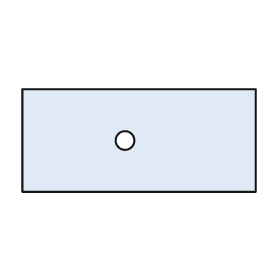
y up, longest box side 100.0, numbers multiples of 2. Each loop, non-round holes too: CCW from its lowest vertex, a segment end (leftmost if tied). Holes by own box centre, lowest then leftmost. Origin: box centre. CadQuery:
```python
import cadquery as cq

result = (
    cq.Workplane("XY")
    .moveTo(-50.0, -22.0)
    .lineTo(50.0, -22.0)
    .lineTo(50.0, 22.0)
    .lineTo(-50.0, 22.0)
    .close()
    .moveTo(-6.0, 0.0)
    .circle(4.0)
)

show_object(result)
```